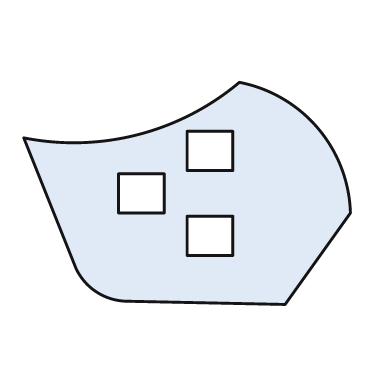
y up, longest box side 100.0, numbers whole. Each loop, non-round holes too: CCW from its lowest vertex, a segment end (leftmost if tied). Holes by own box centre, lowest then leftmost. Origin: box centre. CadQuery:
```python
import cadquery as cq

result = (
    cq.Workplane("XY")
    .moveTo(30.0, -34.0)
    .lineTo(50.0, -6.0)
    .threePointArc((40.0, 20.0), (16.0, 34.0))
    .threePointArc((-15.0, 18.0), (-50.0, 17.0))
    .lineTo(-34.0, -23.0)
    .threePointArc((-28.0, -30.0), (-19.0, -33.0))
    .close()
    .moveTo(0.0, -19.0)
    .lineTo(14.0, -19.0)
    .lineTo(14.0, -7.0)
    .lineTo(0.0, -7.0)
    .close()
    .moveTo(-21.0, -6.0)
    .lineTo(-7.0, -6.0)
    .lineTo(-7.0, 6.0)
    .lineTo(-21.0, 6.0)
    .close()
    .moveTo(0.0, 7.0)
    .lineTo(14.0, 7.0)
    .lineTo(14.0, 19.0)
    .lineTo(0.0, 19.0)
    .close()
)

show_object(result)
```